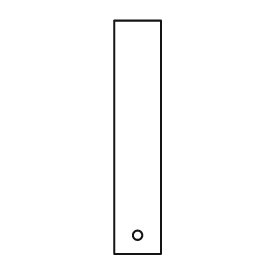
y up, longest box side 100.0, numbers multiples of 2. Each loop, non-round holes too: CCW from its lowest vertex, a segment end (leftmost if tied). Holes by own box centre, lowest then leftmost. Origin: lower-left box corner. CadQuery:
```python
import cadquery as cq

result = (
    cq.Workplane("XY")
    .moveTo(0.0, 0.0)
    .lineTo(20.0, 0.0)
    .lineTo(20.0, 100.0)
    .lineTo(0.0, 100.0)
    .close()
    .moveTo(10.0, 8.0)
    .circle(2.0)
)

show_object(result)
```